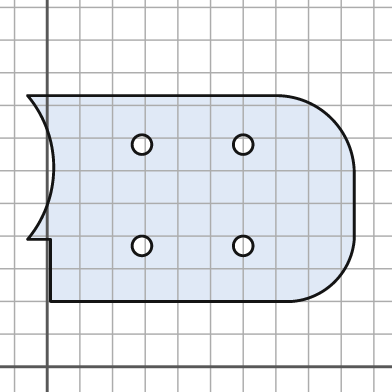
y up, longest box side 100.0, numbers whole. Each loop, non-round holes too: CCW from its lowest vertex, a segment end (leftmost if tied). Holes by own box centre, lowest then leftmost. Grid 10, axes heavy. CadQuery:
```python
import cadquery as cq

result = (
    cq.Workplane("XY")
    .moveTo(1.0, 20.0)
    .lineTo(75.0, 20.0)
    .threePointArc((88.0, 26.0), (94.0, 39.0))
    .lineTo(94.0, 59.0)
    .threePointArc((87.0, 76.0), (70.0, 83.0))
    .lineTo(-6.0, 83.0)
    .threePointArc((2.0, 61.0), (-6.0, 39.0))
    .lineTo(1.0, 39.0)
    .close()
    .moveTo(29.0, 37.0)
    .circle(3.0)
    .moveTo(60.0, 37.0)
    .circle(3.0)
    .moveTo(29.0, 68.0)
    .circle(3.0)
    .moveTo(60.0, 68.0)
    .circle(3.0)
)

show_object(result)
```